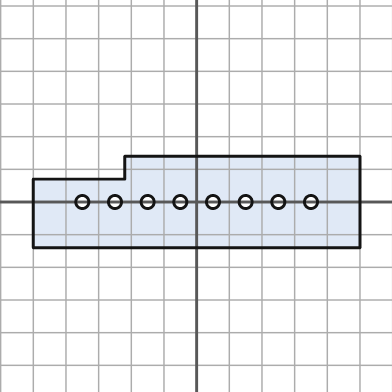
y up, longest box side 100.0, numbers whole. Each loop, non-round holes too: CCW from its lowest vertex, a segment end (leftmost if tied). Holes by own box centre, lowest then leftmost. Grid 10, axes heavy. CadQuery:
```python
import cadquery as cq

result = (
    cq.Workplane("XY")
    .moveTo(-50.0, -14.0)
    .lineTo(50.0, -14.0)
    .lineTo(50.0, 14.0)
    .lineTo(-22.0, 14.0)
    .lineTo(-22.0, 7.0)
    .lineTo(-50.0, 7.0)
    .close()
    .moveTo(-35.0, 0.0)
    .circle(2.0)
    .moveTo(-25.0, 0.0)
    .circle(2.0)
    .moveTo(-15.0, 0.0)
    .circle(2.0)
    .moveTo(-5.0, 0.0)
    .circle(2.0)
    .moveTo(5.0, 0.0)
    .circle(2.0)
    .moveTo(15.0, 0.0)
    .circle(2.0)
    .moveTo(25.0, 0.0)
    .circle(2.0)
    .moveTo(35.0, 0.0)
    .circle(2.0)
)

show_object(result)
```